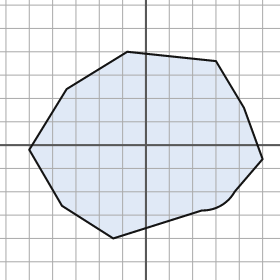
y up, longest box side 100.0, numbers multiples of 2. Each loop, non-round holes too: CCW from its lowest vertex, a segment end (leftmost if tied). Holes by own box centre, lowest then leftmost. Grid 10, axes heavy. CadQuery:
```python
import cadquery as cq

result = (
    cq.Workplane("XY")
    .moveTo(-14.0, -40.0)
    .lineTo(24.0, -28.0)
    .threePointArc((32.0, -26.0), (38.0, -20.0))
    .lineTo(50.0, -6.0)
    .lineTo(42.0, 16.0)
    .lineTo(30.0, 36.0)
    .lineTo(-8.0, 40.0)
    .lineTo(-34.0, 24.0)
    .lineTo(-50.0, -2.0)
    .lineTo(-36.0, -26.0)
    .close()
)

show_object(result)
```